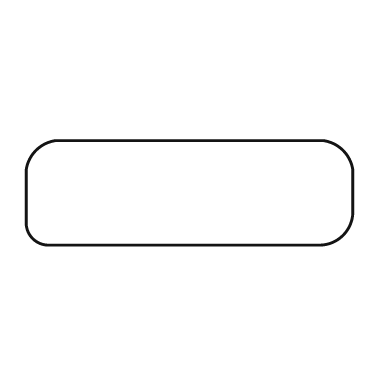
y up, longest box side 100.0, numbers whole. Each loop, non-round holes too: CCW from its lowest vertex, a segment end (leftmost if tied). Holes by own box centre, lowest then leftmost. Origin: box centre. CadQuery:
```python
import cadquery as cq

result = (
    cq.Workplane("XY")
    .moveTo(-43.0, -16.0)
    .lineTo(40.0, -16.0)
    .threePointArc((47.0, -13.0), (50.0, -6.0))
    .lineTo(50.0, 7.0)
    .threePointArc((47.0, 13.0), (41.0, 16.0))
    .lineTo(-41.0, 16.0)
    .threePointArc((-47.0, 13.0), (-50.0, 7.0))
    .lineTo(-50.0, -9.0)
    .threePointArc((-48.0, -14.0), (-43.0, -16.0))
    .close()
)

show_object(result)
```